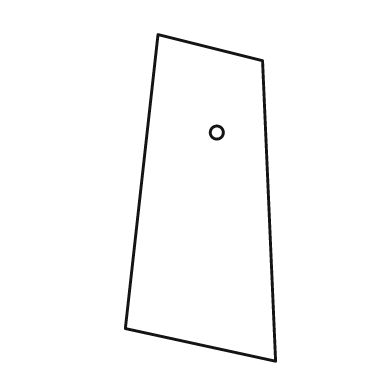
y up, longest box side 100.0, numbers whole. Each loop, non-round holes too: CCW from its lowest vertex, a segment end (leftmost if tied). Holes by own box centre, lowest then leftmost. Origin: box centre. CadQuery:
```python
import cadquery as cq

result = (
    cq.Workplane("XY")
    .moveTo(23.0, -50.0)
    .lineTo(19.0, 42.0)
    .lineTo(-13.0, 50.0)
    .lineTo(-23.0, -40.0)
    .close()
    .moveTo(5.0, 20.0)
    .circle(2.0)
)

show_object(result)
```